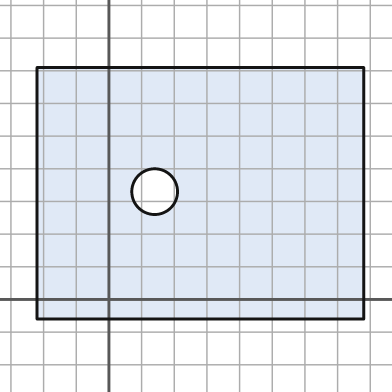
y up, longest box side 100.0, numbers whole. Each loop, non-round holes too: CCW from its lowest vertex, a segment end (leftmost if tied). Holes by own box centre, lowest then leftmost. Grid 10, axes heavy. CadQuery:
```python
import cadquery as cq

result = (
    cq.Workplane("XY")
    .moveTo(-22.0, -6.0)
    .lineTo(78.0, -6.0)
    .lineTo(78.0, 71.0)
    .lineTo(-22.0, 71.0)
    .close()
    .moveTo(14.0, 33.0)
    .circle(7.0)
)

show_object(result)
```